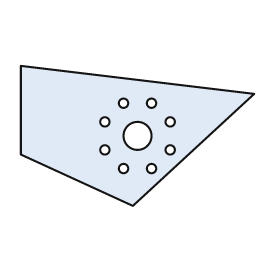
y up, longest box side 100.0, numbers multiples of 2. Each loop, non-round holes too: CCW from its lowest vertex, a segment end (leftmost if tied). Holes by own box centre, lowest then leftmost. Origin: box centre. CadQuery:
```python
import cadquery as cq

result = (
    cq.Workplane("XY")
    .moveTo(-2.0, -30.0)
    .lineTo(50.0, 18.0)
    .lineTo(-50.0, 30.0)
    .lineTo(-50.0, -8.0)
    .close()
    .moveTo(-6.0, -14.0)
    .circle(2.0)
    .moveTo(6.0, -14.0)
    .circle(2.0)
    .moveTo(-14.0, -6.0)
    .circle(2.0)
    .moveTo(14.0, -6.0)
    .circle(2.0)
    .moveTo(0.0, 0.0)
    .circle(6.0)
    .moveTo(-14.0, 6.0)
    .circle(2.0)
    .moveTo(14.0, 6.0)
    .circle(2.0)
    .moveTo(-6.0, 14.0)
    .circle(2.0)
    .moveTo(6.0, 14.0)
    .circle(2.0)
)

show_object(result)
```